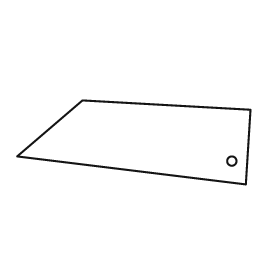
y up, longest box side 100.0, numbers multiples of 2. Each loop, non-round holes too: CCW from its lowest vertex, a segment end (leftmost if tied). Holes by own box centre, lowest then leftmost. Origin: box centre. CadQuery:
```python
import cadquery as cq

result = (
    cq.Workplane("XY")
    .moveTo(48.0, -18.0)
    .lineTo(50.0, 14.0)
    .lineTo(-22.0, 18.0)
    .lineTo(-50.0, -6.0)
    .close()
    .moveTo(42.0, -8.0)
    .circle(2.0)
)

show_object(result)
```